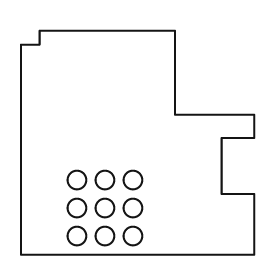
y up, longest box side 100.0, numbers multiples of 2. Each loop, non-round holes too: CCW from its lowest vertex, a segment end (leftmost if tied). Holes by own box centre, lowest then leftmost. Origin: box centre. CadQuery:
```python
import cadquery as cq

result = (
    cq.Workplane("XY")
    .moveTo(-50.0, -48.0)
    .lineTo(50.0, -48.0)
    .lineTo(50.0, -22.0)
    .lineTo(36.0, -22.0)
    .lineTo(36.0, 2.0)
    .lineTo(50.0, 2.0)
    .lineTo(50.0, 12.0)
    .lineTo(16.0, 12.0)
    .lineTo(16.0, 48.0)
    .lineTo(-42.0, 48.0)
    .lineTo(-42.0, 42.0)
    .lineTo(-50.0, 42.0)
    .close()
    .moveTo(-26.0, -40.0)
    .circle(4.0)
    .moveTo(-14.0, -40.0)
    .circle(4.0)
    .moveTo(-2.0, -40.0)
    .circle(4.0)
    .moveTo(-26.0, -28.0)
    .circle(4.0)
    .moveTo(-14.0, -28.0)
    .circle(4.0)
    .moveTo(-2.0, -28.0)
    .circle(4.0)
    .moveTo(-26.0, -16.0)
    .circle(4.0)
    .moveTo(-14.0, -16.0)
    .circle(4.0)
    .moveTo(-2.0, -16.0)
    .circle(4.0)
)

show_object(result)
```